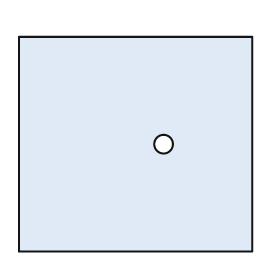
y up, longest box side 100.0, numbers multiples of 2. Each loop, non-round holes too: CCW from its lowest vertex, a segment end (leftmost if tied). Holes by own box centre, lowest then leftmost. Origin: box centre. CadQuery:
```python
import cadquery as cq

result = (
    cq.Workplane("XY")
    .moveTo(-50.0, -46.0)
    .lineTo(50.0, -46.0)
    .lineTo(50.0, 46.0)
    .lineTo(-50.0, 46.0)
    .close()
    .moveTo(12.0, 0.0)
    .circle(4.0)
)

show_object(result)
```